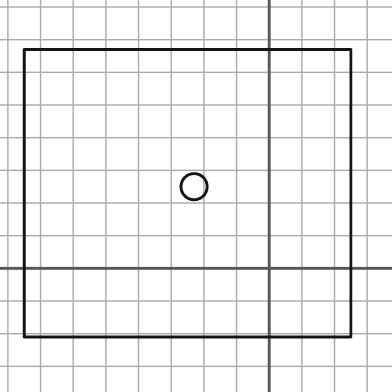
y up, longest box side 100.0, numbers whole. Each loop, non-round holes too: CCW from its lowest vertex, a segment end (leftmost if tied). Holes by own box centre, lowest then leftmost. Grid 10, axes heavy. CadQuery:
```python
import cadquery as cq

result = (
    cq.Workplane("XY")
    .moveTo(-75.0, -21.0)
    .lineTo(25.0, -21.0)
    .lineTo(25.0, 67.0)
    .lineTo(-75.0, 67.0)
    .close()
    .moveTo(-23.0, 25.0)
    .circle(4.0)
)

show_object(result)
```